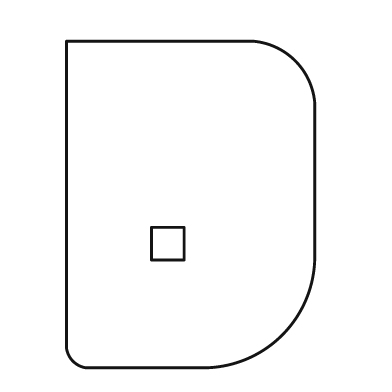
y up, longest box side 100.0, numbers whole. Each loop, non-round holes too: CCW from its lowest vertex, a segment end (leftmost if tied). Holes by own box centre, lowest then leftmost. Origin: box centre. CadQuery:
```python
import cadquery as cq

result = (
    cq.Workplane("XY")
    .moveTo(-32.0, -50.0)
    .lineTo(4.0, -50.0)
    .threePointArc((28.0, -40.0), (38.0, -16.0))
    .lineTo(38.0, 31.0)
    .threePointArc((32.0, 44.0), (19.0, 50.0))
    .lineTo(-38.0, 50.0)
    .lineTo(-38.0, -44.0)
    .threePointArc((-36.0, -48.0), (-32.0, -50.0))
    .close()
    .moveTo(-12.0, -17.0)
    .lineTo(-2.0, -17.0)
    .lineTo(-2.0, -7.0)
    .lineTo(-12.0, -7.0)
    .close()
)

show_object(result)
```